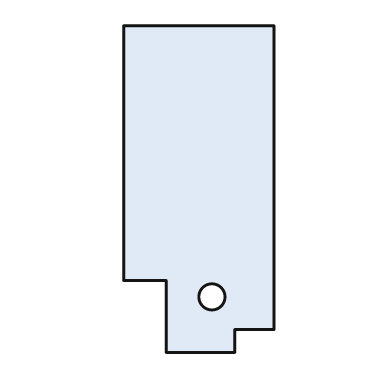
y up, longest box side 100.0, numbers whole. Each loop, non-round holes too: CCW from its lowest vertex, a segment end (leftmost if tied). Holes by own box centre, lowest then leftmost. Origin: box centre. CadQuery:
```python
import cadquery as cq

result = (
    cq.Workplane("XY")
    .moveTo(-10.0, -50.0)
    .lineTo(11.0, -50.0)
    .lineTo(11.0, -43.0)
    .lineTo(23.0, -43.0)
    .lineTo(23.0, 50.0)
    .lineTo(-23.0, 50.0)
    .lineTo(-23.0, -28.0)
    .lineTo(-10.0, -28.0)
    .close()
    .moveTo(4.0, -33.0)
    .circle(4.0)
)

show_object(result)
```